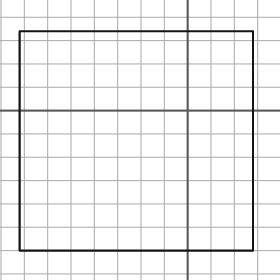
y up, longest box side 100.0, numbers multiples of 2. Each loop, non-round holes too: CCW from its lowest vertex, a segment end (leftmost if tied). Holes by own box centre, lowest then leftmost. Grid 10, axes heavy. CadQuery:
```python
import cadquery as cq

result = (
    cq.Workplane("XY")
    .moveTo(-72.0, -60.0)
    .lineTo(28.0, -60.0)
    .lineTo(28.0, 34.0)
    .lineTo(-72.0, 34.0)
    .close()
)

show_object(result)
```